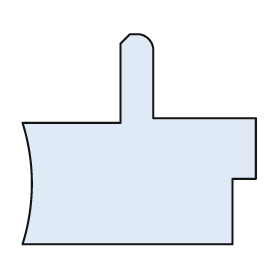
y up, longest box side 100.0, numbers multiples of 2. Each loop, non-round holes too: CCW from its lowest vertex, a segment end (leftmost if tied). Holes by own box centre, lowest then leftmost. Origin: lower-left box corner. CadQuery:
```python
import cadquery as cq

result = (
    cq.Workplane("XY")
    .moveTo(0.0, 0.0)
    .lineTo(90.0, 0.0)
    .lineTo(90.0, 28.0)
    .lineTo(100.0, 28.0)
    .lineTo(100.0, 54.0)
    .lineTo(56.0, 54.0)
    .lineTo(56.0, 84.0)
    .threePointArc((54.0, 88.0), (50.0, 90.0))
    .lineTo(46.0, 90.0)
    .lineTo(42.0, 86.0)
    .lineTo(42.0, 52.0)
    .lineTo(0.0, 52.0)
    .threePointArc((4.0, 26.0), (0.0, 0.0))
    .close()
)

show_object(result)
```